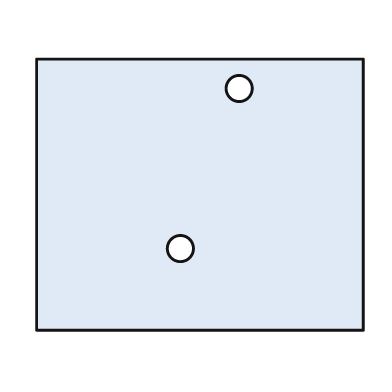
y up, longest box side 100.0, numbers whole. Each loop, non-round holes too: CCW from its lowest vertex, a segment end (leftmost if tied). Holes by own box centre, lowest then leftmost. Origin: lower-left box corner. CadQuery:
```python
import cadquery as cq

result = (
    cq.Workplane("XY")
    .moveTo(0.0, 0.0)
    .lineTo(100.0, 0.0)
    .lineTo(100.0, 83.0)
    .lineTo(0.0, 83.0)
    .close()
    .moveTo(44.0, 25.0)
    .circle(4.0)
    .moveTo(62.0, 74.0)
    .circle(4.0)
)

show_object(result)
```